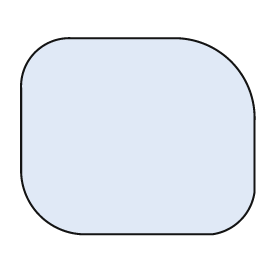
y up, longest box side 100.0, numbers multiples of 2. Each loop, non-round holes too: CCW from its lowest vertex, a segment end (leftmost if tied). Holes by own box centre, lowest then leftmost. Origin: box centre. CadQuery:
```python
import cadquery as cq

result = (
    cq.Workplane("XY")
    .moveTo(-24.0, -42.0)
    .lineTo(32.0, -42.0)
    .threePointArc((44.0, -36.0), (50.0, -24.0))
    .lineTo(50.0, 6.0)
    .threePointArc((40.0, 32.0), (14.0, 42.0))
    .lineTo(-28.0, 42.0)
    .threePointArc((-44.0, 36.0), (-50.0, 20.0))
    .lineTo(-50.0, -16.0)
    .threePointArc((-42.0, -34.0), (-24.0, -42.0))
    .close()
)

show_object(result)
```